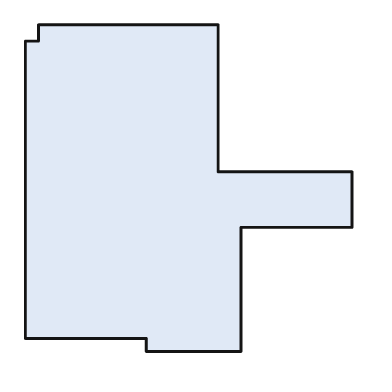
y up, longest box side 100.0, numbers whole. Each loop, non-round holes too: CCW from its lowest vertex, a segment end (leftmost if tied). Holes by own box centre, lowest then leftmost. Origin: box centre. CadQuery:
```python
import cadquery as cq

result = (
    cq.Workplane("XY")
    .moveTo(-13.0, -50.0)
    .lineTo(16.0, -50.0)
    .lineTo(16.0, -12.0)
    .lineTo(50.0, -12.0)
    .lineTo(50.0, 5.0)
    .lineTo(9.0, 5.0)
    .lineTo(9.0, 50.0)
    .lineTo(-46.0, 50.0)
    .lineTo(-46.0, 45.0)
    .lineTo(-50.0, 45.0)
    .lineTo(-50.0, -46.0)
    .lineTo(-13.0, -46.0)
    .close()
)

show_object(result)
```